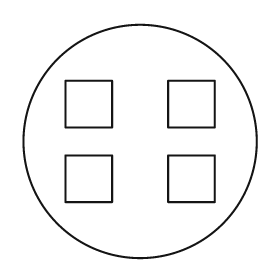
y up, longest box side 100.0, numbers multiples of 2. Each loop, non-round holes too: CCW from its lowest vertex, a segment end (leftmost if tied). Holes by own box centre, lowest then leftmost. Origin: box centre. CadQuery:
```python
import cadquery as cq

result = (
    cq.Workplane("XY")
    .moveTo(0.0, 0.0)
    .circle(50.0)
    .moveTo(-32.0, -26.0)
    .lineTo(-12.0, -26.0)
    .lineTo(-12.0, -6.0)
    .lineTo(-32.0, -6.0)
    .close()
    .moveTo(12.0, -26.0)
    .lineTo(32.0, -26.0)
    .lineTo(32.0, -6.0)
    .lineTo(12.0, -6.0)
    .close()
    .moveTo(-32.0, 6.0)
    .lineTo(-12.0, 6.0)
    .lineTo(-12.0, 26.0)
    .lineTo(-32.0, 26.0)
    .close()
    .moveTo(12.0, 6.0)
    .lineTo(32.0, 6.0)
    .lineTo(32.0, 26.0)
    .lineTo(12.0, 26.0)
    .close()
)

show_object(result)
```